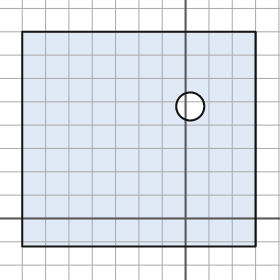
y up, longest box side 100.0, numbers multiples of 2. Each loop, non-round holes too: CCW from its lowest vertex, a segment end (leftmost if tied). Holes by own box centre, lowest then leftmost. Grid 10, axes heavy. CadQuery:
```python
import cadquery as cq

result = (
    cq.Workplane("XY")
    .moveTo(-70.0, -12.0)
    .lineTo(30.0, -12.0)
    .lineTo(30.0, 80.0)
    .lineTo(-70.0, 80.0)
    .close()
    .moveTo(2.0, 48.0)
    .circle(6.0)
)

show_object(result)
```